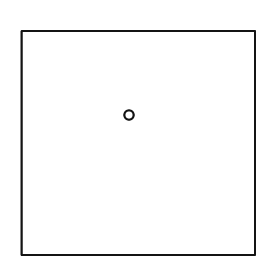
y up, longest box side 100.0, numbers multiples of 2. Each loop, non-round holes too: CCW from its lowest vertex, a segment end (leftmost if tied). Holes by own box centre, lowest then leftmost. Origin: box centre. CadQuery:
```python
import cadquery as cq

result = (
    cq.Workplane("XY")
    .moveTo(-50.0, -48.0)
    .lineTo(50.0, -48.0)
    .lineTo(50.0, 48.0)
    .lineTo(-50.0, 48.0)
    .close()
    .moveTo(-4.0, 12.0)
    .circle(2.0)
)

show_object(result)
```